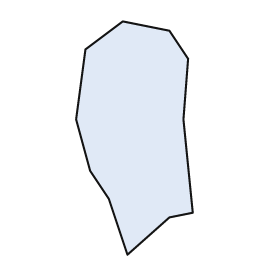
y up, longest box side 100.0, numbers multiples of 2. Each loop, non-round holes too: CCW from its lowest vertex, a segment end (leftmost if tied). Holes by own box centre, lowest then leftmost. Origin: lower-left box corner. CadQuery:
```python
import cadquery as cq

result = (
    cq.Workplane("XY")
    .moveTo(22.0, 0.0)
    .lineTo(40.0, 16.0)
    .lineTo(50.0, 18.0)
    .lineTo(46.0, 58.0)
    .lineTo(48.0, 84.0)
    .lineTo(40.0, 96.0)
    .lineTo(20.0, 100.0)
    .lineTo(4.0, 88.0)
    .lineTo(0.0, 58.0)
    .lineTo(6.0, 36.0)
    .lineTo(14.0, 24.0)
    .close()
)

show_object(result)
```